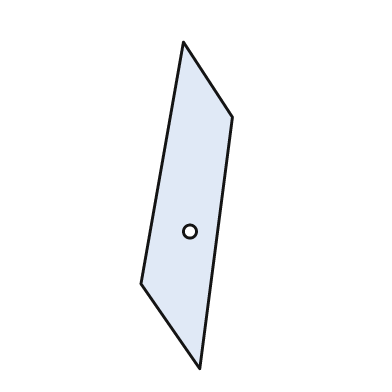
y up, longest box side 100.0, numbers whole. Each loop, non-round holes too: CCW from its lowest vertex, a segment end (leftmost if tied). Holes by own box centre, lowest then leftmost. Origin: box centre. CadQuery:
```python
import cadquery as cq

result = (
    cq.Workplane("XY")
    .moveTo(4.0, -50.0)
    .lineTo(14.0, 27.0)
    .lineTo(-1.0, 50.0)
    .lineTo(-14.0, -24.0)
    .close()
    .moveTo(1.0, -8.0)
    .circle(2.0)
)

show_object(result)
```